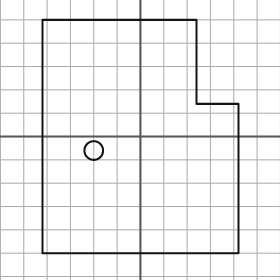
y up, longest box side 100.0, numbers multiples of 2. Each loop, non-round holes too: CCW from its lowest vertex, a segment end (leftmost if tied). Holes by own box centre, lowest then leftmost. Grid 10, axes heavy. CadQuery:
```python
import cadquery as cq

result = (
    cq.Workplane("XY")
    .moveTo(-42.0, -50.0)
    .lineTo(42.0, -50.0)
    .lineTo(42.0, 14.0)
    .lineTo(24.0, 14.0)
    .lineTo(24.0, 50.0)
    .lineTo(-42.0, 50.0)
    .close()
    .moveTo(-20.0, -6.0)
    .circle(4.0)
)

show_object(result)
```